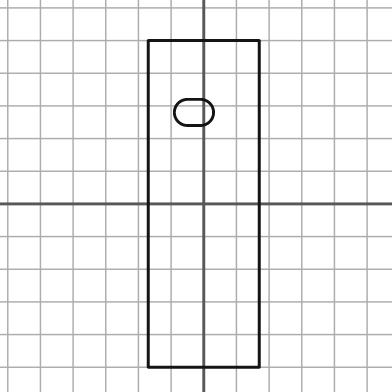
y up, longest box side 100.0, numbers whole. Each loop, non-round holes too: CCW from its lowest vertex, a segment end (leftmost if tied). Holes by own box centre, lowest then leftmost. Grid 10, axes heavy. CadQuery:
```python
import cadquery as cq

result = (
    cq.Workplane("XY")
    .moveTo(-17.0, -50.0)
    .lineTo(17.0, -50.0)
    .lineTo(17.0, 50.0)
    .lineTo(-17.0, 50.0)
    .close()
    .moveTo(-5.0, 24.0)
    .lineTo(-1.0, 24.0)
    .threePointArc((3.0, 28.0), (-1.0, 32.0))
    .lineTo(-5.0, 32.0)
    .threePointArc((-9.0, 28.0), (-5.0, 24.0))
    .close()
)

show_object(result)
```